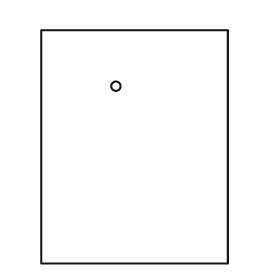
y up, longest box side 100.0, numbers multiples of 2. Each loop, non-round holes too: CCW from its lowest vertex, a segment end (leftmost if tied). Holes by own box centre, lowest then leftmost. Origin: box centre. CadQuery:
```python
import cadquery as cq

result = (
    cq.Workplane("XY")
    .moveTo(-40.0, -50.0)
    .lineTo(40.0, -50.0)
    .lineTo(40.0, 50.0)
    .lineTo(-40.0, 50.0)
    .close()
    .moveTo(-8.0, 26.0)
    .circle(2.0)
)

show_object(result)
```